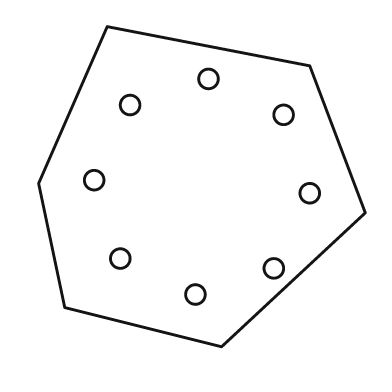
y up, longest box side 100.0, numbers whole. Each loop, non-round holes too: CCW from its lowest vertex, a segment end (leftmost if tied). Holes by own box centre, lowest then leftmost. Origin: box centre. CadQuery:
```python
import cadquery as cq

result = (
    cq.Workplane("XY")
    .moveTo(6.0, -49.0)
    .lineTo(50.0, -8.0)
    .lineTo(33.0, 37.0)
    .lineTo(-29.0, 49.0)
    .lineTo(-50.0, 1.0)
    .lineTo(-42.0, -37.0)
    .close()
    .moveTo(-2.0, -33.0)
    .circle(3.0)
    .moveTo(22.0, -25.0)
    .circle(3.0)
    .moveTo(-25.0, -22.0)
    .circle(3.0)
    .moveTo(33.0, -2.0)
    .circle(3.0)
    .moveTo(-33.0, 2.0)
    .circle(3.0)
    .moveTo(25.0, 22.0)
    .circle(3.0)
    .moveTo(-22.0, 25.0)
    .circle(3.0)
    .moveTo(2.0, 33.0)
    .circle(3.0)
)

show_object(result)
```